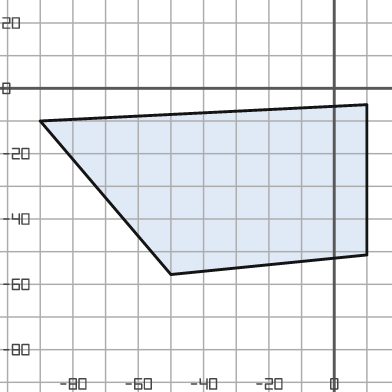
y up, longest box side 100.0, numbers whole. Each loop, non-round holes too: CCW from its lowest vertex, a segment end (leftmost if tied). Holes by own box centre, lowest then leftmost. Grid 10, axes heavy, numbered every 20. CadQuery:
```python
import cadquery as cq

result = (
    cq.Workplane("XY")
    .moveTo(-50.0, -57.0)
    .lineTo(10.0, -51.0)
    .lineTo(10.0, -5.0)
    .lineTo(-90.0, -10.0)
    .close()
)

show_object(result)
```